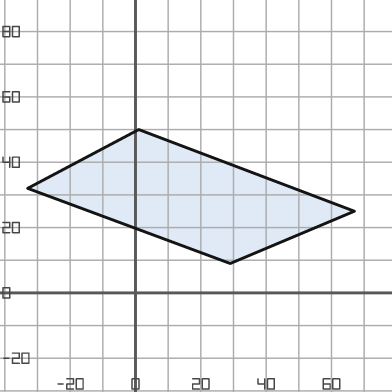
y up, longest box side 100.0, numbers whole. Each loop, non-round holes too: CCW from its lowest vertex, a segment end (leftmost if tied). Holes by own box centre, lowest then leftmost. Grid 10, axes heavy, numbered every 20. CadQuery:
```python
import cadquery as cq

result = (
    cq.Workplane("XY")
    .moveTo(29.0, 9.0)
    .lineTo(67.0, 25.0)
    .lineTo(1.0, 50.0)
    .lineTo(-33.0, 32.0)
    .close()
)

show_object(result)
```